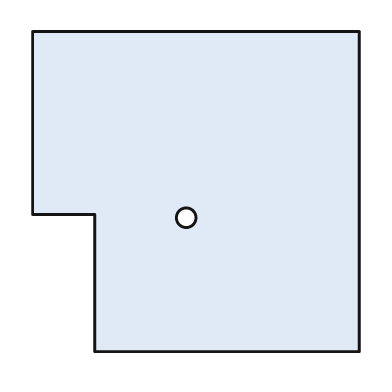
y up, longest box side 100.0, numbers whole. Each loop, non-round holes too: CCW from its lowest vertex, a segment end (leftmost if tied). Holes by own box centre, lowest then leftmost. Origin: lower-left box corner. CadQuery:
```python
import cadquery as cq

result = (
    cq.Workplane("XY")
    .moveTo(19.0, 0.0)
    .lineTo(100.0, 0.0)
    .lineTo(100.0, 98.0)
    .lineTo(0.0, 98.0)
    .lineTo(0.0, 42.0)
    .lineTo(19.0, 42.0)
    .close()
    .moveTo(47.0, 41.0)
    .circle(3.0)
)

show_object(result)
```